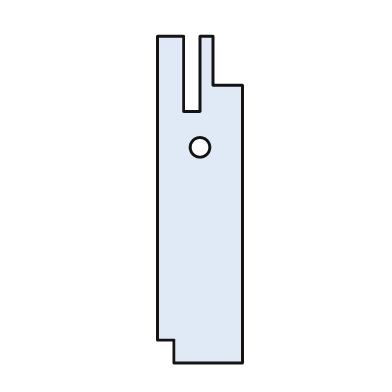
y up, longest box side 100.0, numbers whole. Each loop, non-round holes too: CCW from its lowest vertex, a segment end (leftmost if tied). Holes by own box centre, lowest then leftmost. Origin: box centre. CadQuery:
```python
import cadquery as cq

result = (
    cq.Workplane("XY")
    .moveTo(-8.0, -50.0)
    .lineTo(13.0, -50.0)
    .lineTo(13.0, 35.0)
    .lineTo(4.0, 35.0)
    .lineTo(4.0, 50.0)
    .lineTo(0.0, 50.0)
    .lineTo(0.0, 27.0)
    .lineTo(-5.0, 27.0)
    .lineTo(-5.0, 50.0)
    .lineTo(-13.0, 50.0)
    .lineTo(-13.0, -43.0)
    .lineTo(-8.0, -43.0)
    .close()
    .moveTo(0.0, 16.0)
    .circle(3.0)
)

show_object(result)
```